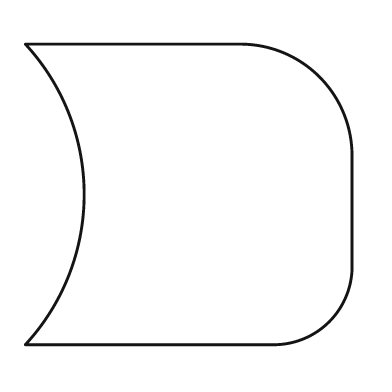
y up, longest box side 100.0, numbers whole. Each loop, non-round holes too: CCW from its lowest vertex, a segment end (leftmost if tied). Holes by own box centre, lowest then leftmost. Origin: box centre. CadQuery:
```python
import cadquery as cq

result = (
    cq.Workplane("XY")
    .moveTo(-50.0, -46.0)
    .lineTo(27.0, -46.0)
    .threePointArc((43.0, -39.0), (50.0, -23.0))
    .lineTo(50.0, 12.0)
    .threePointArc((40.0, 36.0), (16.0, 46.0))
    .lineTo(-50.0, 46.0)
    .threePointArc((-32.0, 0.0), (-50.0, -46.0))
    .close()
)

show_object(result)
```